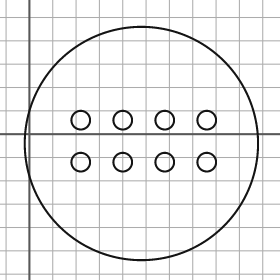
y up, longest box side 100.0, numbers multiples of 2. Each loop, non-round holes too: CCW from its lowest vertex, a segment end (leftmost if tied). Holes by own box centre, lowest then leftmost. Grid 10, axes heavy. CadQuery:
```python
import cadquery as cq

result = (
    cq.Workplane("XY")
    .moveTo(48.0, -4.0)
    .circle(50.0)
    .moveTo(22.0, -12.0)
    .circle(4.0)
    .moveTo(40.0, -12.0)
    .circle(4.0)
    .moveTo(58.0, -12.0)
    .circle(4.0)
    .moveTo(76.0, -12.0)
    .circle(4.0)
    .moveTo(22.0, 6.0)
    .circle(4.0)
    .moveTo(40.0, 6.0)
    .circle(4.0)
    .moveTo(58.0, 6.0)
    .circle(4.0)
    .moveTo(76.0, 6.0)
    .circle(4.0)
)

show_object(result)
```